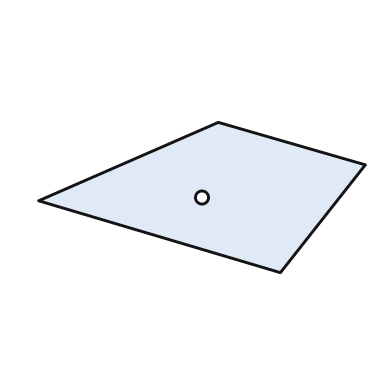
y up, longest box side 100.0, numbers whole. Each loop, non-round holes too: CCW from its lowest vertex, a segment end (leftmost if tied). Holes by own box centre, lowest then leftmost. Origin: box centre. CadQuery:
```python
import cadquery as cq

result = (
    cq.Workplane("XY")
    .moveTo(24.0, -23.0)
    .lineTo(50.0, 10.0)
    .lineTo(5.0, 23.0)
    .lineTo(-50.0, -1.0)
    .close()
    .moveTo(0.0, 0.0)
    .circle(2.0)
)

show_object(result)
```